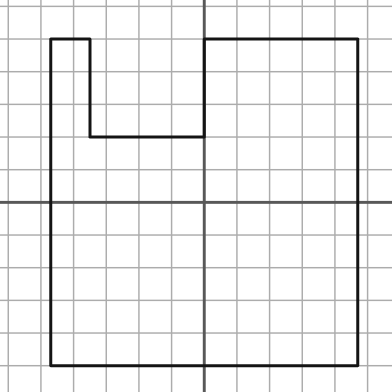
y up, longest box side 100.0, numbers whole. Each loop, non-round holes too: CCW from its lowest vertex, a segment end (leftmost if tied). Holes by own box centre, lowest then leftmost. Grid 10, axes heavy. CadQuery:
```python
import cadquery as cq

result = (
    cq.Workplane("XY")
    .moveTo(-47.0, -50.0)
    .lineTo(47.0, -50.0)
    .lineTo(47.0, 50.0)
    .lineTo(0.0, 50.0)
    .lineTo(0.0, 20.0)
    .lineTo(-35.0, 20.0)
    .lineTo(-35.0, 50.0)
    .lineTo(-47.0, 50.0)
    .close()
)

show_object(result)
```